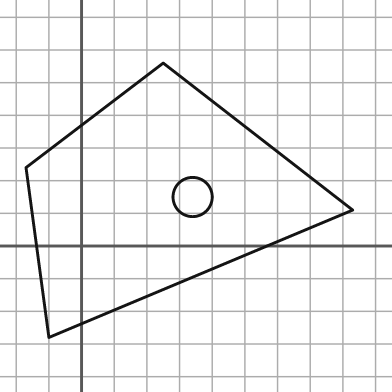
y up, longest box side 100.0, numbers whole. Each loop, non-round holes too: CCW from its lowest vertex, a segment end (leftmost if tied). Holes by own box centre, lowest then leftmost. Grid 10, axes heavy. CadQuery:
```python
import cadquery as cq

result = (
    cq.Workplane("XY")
    .moveTo(-10.0, -28.0)
    .lineTo(83.0, 11.0)
    .lineTo(25.0, 56.0)
    .lineTo(-17.0, 24.0)
    .close()
    .moveTo(34.0, 15.0)
    .circle(6.0)
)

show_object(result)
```